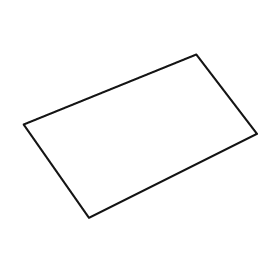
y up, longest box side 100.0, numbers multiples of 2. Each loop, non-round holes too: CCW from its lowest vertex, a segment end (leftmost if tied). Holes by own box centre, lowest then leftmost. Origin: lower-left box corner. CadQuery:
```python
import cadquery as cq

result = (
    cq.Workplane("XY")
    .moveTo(28.0, 0.0)
    .lineTo(100.0, 36.0)
    .lineTo(74.0, 70.0)
    .lineTo(0.0, 40.0)
    .close()
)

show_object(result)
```